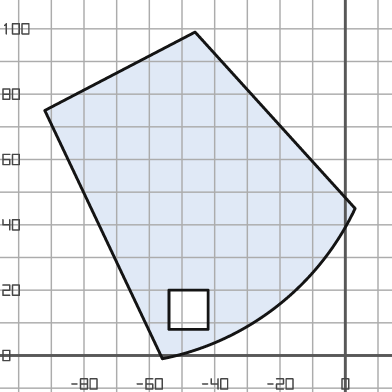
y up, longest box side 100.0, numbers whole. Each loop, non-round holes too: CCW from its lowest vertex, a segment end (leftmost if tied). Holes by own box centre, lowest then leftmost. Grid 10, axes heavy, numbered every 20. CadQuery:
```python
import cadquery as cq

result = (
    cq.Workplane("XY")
    .moveTo(-56.0, -1.0)
    .threePointArc((-21.0, 15.0), (3.0, 45.0))
    .lineTo(-46.0, 99.0)
    .lineTo(-92.0, 75.0)
    .close()
    .moveTo(-54.0, 8.0)
    .lineTo(-42.0, 8.0)
    .lineTo(-42.0, 20.0)
    .lineTo(-54.0, 20.0)
    .close()
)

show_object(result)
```